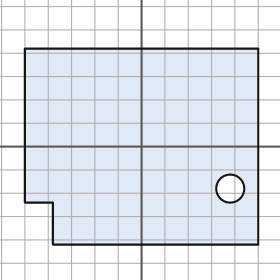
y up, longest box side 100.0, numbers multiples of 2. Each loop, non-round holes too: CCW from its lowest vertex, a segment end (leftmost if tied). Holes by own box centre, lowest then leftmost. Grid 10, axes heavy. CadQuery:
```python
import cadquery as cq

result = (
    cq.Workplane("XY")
    .moveTo(-38.0, -42.0)
    .lineTo(50.0, -42.0)
    .lineTo(50.0, 42.0)
    .lineTo(-50.0, 42.0)
    .lineTo(-50.0, -24.0)
    .lineTo(-38.0, -24.0)
    .close()
    .moveTo(38.0, -18.0)
    .circle(6.0)
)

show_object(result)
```